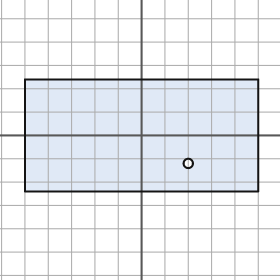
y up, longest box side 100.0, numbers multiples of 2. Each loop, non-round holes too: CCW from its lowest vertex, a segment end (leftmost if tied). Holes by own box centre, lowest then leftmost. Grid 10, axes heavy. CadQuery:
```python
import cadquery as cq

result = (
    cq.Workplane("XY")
    .moveTo(-50.0, -24.0)
    .lineTo(50.0, -24.0)
    .lineTo(50.0, 24.0)
    .lineTo(-50.0, 24.0)
    .close()
    .moveTo(20.0, -12.0)
    .circle(2.0)
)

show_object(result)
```